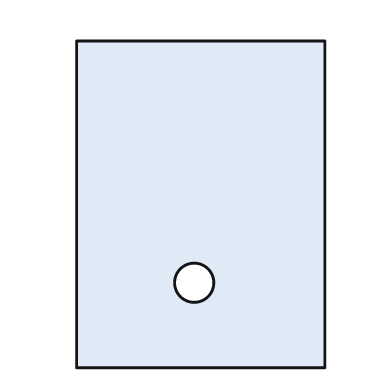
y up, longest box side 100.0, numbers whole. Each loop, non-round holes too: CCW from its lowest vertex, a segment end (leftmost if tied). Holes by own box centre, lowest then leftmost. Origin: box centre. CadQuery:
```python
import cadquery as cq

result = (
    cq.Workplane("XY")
    .moveTo(-38.0, -50.0)
    .lineTo(38.0, -50.0)
    .lineTo(38.0, 50.0)
    .lineTo(-38.0, 50.0)
    .close()
    .moveTo(-2.0, -24.0)
    .circle(6.0)
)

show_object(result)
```